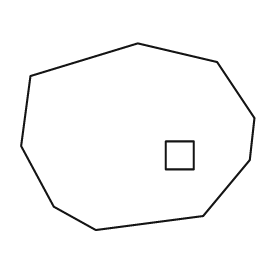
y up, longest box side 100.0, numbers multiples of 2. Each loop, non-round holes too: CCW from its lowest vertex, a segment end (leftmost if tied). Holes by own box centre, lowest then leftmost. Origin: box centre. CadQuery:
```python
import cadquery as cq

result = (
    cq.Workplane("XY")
    .moveTo(-18.0, -40.0)
    .lineTo(28.0, -34.0)
    .lineTo(48.0, -10.0)
    .lineTo(50.0, 8.0)
    .lineTo(34.0, 32.0)
    .lineTo(0.0, 40.0)
    .lineTo(-46.0, 26.0)
    .lineTo(-50.0, -4.0)
    .lineTo(-36.0, -30.0)
    .close()
    .moveTo(12.0, -14.0)
    .lineTo(24.0, -14.0)
    .lineTo(24.0, -2.0)
    .lineTo(12.0, -2.0)
    .close()
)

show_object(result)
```